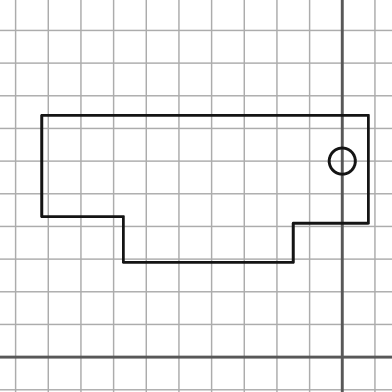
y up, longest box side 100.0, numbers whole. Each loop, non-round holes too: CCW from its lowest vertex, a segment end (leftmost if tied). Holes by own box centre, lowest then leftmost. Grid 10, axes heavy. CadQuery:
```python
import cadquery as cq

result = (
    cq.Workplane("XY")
    .moveTo(-67.0, 29.0)
    .lineTo(-15.0, 29.0)
    .lineTo(-15.0, 41.0)
    .lineTo(8.0, 41.0)
    .lineTo(8.0, 74.0)
    .lineTo(-92.0, 74.0)
    .lineTo(-92.0, 43.0)
    .lineTo(-67.0, 43.0)
    .close()
    .moveTo(0.0, 60.0)
    .circle(4.0)
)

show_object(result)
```